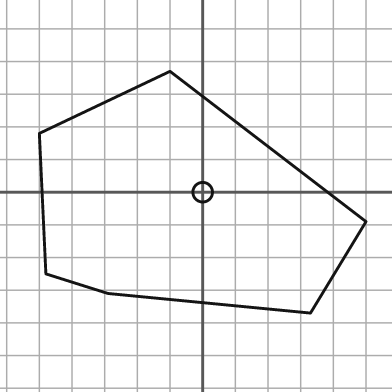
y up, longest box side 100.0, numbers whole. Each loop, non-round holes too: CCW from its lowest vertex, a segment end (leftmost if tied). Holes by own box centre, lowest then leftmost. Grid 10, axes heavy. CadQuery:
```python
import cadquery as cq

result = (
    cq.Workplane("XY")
    .moveTo(33.0, -37.0)
    .lineTo(50.0, -9.0)
    .lineTo(-10.0, 37.0)
    .lineTo(-50.0, 18.0)
    .lineTo(-48.0, -25.0)
    .lineTo(-29.0, -31.0)
    .close()
    .moveTo(0.0, 0.0)
    .circle(3.0)
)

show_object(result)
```